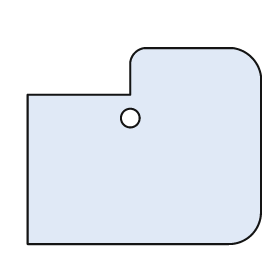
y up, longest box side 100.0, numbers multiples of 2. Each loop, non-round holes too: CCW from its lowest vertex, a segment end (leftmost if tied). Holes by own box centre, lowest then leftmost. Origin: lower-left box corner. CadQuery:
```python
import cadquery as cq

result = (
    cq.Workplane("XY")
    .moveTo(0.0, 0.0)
    .lineTo(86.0, 0.0)
    .threePointArc((96.0, 4.0), (100.0, 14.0))
    .lineTo(100.0, 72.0)
    .threePointArc((96.0, 80.0), (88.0, 84.0))
    .lineTo(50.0, 84.0)
    .threePointArc((46.0, 82.0), (44.0, 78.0))
    .lineTo(44.0, 64.0)
    .lineTo(0.0, 64.0)
    .close()
    .moveTo(44.0, 54.0)
    .circle(4.0)
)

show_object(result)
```